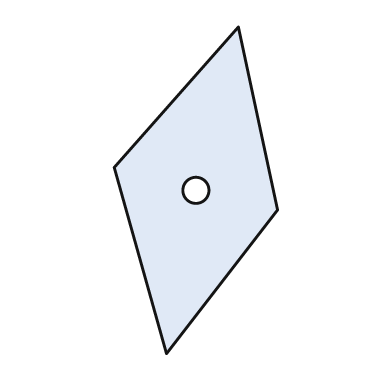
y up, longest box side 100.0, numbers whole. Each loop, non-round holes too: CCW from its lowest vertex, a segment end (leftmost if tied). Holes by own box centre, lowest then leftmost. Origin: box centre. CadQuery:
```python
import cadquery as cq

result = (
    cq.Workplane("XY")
    .moveTo(-9.0, -50.0)
    .lineTo(25.0, -6.0)
    .lineTo(13.0, 50.0)
    .lineTo(-25.0, 7.0)
    .close()
    .moveTo(0.0, 0.0)
    .circle(4.0)
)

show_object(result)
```